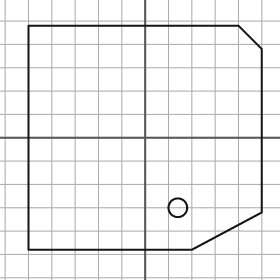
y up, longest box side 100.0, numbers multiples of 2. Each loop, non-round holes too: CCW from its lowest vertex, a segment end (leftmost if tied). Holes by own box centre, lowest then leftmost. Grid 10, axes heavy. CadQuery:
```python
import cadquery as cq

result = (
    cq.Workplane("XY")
    .moveTo(-50.0, -48.0)
    .lineTo(20.0, -48.0)
    .lineTo(50.0, -32.0)
    .lineTo(50.0, 38.0)
    .lineTo(40.0, 48.0)
    .lineTo(-50.0, 48.0)
    .close()
    .moveTo(14.0, -30.0)
    .circle(4.0)
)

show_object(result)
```